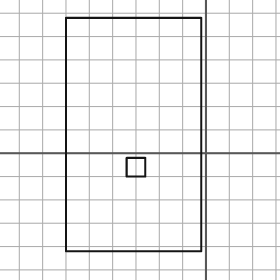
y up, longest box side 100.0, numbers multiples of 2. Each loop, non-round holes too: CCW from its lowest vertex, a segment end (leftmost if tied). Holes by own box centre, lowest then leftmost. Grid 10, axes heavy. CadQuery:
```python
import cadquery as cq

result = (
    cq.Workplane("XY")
    .moveTo(-60.0, -42.0)
    .lineTo(-2.0, -42.0)
    .lineTo(-2.0, 58.0)
    .lineTo(-60.0, 58.0)
    .close()
    .moveTo(-34.0, -10.0)
    .lineTo(-26.0, -10.0)
    .lineTo(-26.0, -2.0)
    .lineTo(-34.0, -2.0)
    .close()
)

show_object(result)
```